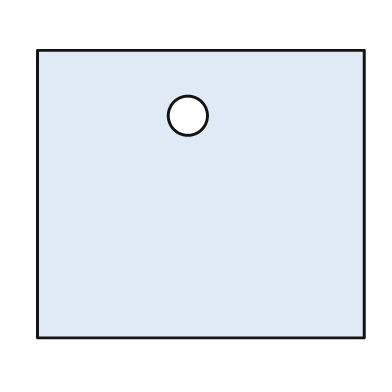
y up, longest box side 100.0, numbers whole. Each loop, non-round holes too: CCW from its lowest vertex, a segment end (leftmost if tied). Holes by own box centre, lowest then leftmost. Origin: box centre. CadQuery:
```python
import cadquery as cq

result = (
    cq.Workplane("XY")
    .moveTo(-50.0, -44.0)
    .lineTo(50.0, -44.0)
    .lineTo(50.0, 44.0)
    .lineTo(-50.0, 44.0)
    .close()
    .moveTo(-4.0, 24.0)
    .circle(6.0)
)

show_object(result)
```